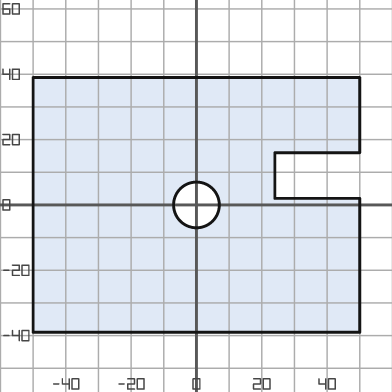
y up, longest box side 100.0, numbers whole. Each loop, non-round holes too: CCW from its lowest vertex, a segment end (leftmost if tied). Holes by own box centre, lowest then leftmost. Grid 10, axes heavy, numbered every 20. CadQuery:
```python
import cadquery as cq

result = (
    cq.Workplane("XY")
    .moveTo(-50.0, -39.0)
    .lineTo(50.0, -39.0)
    .lineTo(50.0, 2.0)
    .lineTo(24.0, 2.0)
    .lineTo(24.0, 16.0)
    .lineTo(50.0, 16.0)
    .lineTo(50.0, 39.0)
    .lineTo(-50.0, 39.0)
    .close()
    .moveTo(0.0, 0.0)
    .circle(7.0)
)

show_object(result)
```